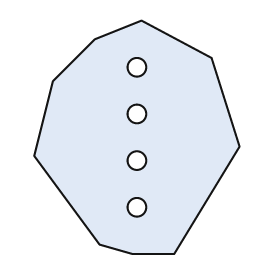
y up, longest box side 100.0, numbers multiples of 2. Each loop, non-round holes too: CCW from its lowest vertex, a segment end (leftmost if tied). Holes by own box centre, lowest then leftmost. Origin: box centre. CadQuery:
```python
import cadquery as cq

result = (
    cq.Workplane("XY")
    .moveTo(-2.0, -50.0)
    .lineTo(16.0, -50.0)
    .lineTo(44.0, -4.0)
    .lineTo(32.0, 34.0)
    .lineTo(2.0, 50.0)
    .lineTo(-18.0, 42.0)
    .lineTo(-36.0, 24.0)
    .lineTo(-44.0, -8.0)
    .lineTo(-16.0, -46.0)
    .close()
    .moveTo(0.0, -30.0)
    .circle(4.0)
    .moveTo(0.0, -10.0)
    .circle(4.0)
    .moveTo(0.0, 10.0)
    .circle(4.0)
    .moveTo(0.0, 30.0)
    .circle(4.0)
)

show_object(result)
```